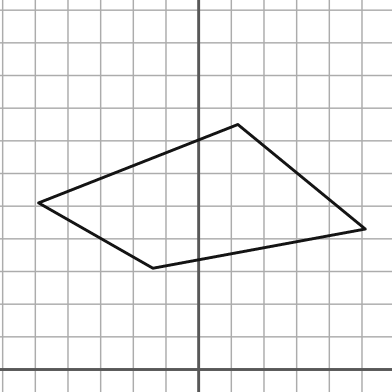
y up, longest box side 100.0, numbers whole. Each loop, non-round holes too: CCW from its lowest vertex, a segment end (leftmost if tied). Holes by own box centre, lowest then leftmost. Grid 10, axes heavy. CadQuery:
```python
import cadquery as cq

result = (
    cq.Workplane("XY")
    .moveTo(-14.0, 31.0)
    .lineTo(51.0, 43.0)
    .lineTo(12.0, 75.0)
    .lineTo(-49.0, 51.0)
    .close()
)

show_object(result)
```